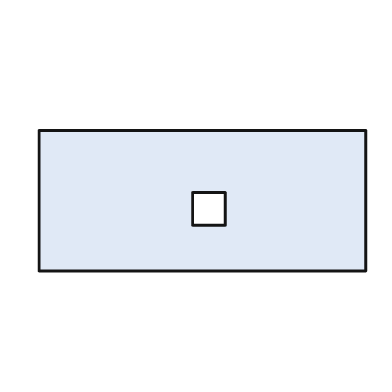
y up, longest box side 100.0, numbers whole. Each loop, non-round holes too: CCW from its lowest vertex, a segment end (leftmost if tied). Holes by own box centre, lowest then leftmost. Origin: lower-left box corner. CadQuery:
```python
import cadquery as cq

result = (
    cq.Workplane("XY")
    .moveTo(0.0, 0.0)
    .lineTo(100.0, 0.0)
    .lineTo(100.0, 43.0)
    .lineTo(0.0, 43.0)
    .close()
    .moveTo(47.0, 14.0)
    .lineTo(57.0, 14.0)
    .lineTo(57.0, 24.0)
    .lineTo(47.0, 24.0)
    .close()
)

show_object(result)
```